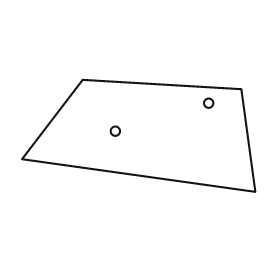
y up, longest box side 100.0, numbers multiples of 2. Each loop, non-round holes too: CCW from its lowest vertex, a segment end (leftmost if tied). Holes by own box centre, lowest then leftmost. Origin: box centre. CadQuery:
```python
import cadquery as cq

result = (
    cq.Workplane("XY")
    .moveTo(50.0, -24.0)
    .lineTo(44.0, 20.0)
    .lineTo(-24.0, 24.0)
    .lineTo(-50.0, -10.0)
    .close()
    .moveTo(-10.0, 2.0)
    .circle(2.0)
    .moveTo(30.0, 14.0)
    .circle(2.0)
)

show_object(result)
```